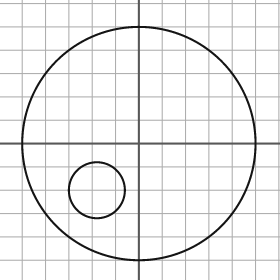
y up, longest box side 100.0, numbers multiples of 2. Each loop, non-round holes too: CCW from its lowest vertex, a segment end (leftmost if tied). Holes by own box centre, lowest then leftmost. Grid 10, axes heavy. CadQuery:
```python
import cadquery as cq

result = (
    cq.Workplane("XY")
    .moveTo(0.0, 0.0)
    .circle(50.0)
    .moveTo(-18.0, -20.0)
    .circle(12.0)
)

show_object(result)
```